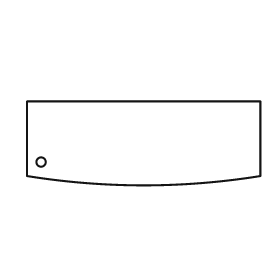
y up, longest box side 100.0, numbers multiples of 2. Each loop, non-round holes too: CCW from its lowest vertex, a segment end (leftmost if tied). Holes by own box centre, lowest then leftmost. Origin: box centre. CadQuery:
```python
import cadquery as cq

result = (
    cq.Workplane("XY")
    .moveTo(-50.0, -14.0)
    .threePointArc((0.0, -18.0), (50.0, -14.0))
    .lineTo(50.0, 18.0)
    .lineTo(-50.0, 18.0)
    .close()
    .moveTo(-44.0, -8.0)
    .circle(2.0)
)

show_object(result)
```